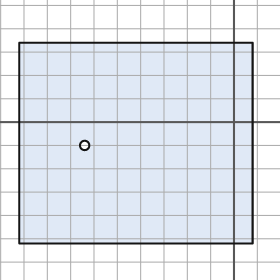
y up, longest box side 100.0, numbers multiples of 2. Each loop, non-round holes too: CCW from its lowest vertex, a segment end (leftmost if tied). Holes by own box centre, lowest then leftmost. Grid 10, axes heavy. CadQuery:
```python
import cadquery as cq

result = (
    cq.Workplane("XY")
    .moveTo(-92.0, -52.0)
    .lineTo(8.0, -52.0)
    .lineTo(8.0, 34.0)
    .lineTo(-92.0, 34.0)
    .close()
    .moveTo(-64.0, -10.0)
    .circle(2.0)
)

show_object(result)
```